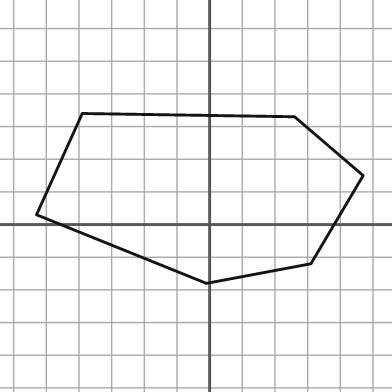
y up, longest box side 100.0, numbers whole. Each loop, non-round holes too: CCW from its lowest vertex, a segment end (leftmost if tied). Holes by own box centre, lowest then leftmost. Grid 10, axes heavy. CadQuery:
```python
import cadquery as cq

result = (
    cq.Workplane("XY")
    .moveTo(-1.0, -18.0)
    .lineTo(31.0, -12.0)
    .lineTo(47.0, 15.0)
    .lineTo(26.0, 33.0)
    .lineTo(-39.0, 34.0)
    .lineTo(-53.0, 3.0)
    .close()
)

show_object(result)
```